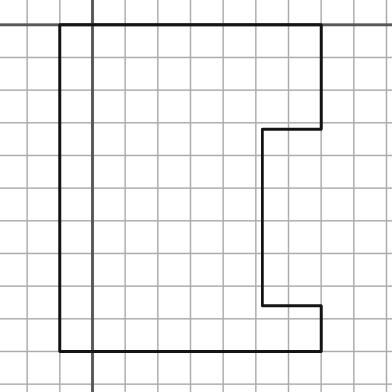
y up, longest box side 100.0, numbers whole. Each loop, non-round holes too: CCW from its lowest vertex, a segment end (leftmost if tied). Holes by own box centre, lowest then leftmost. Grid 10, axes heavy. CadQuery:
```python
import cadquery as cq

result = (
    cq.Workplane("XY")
    .moveTo(-10.0, -100.0)
    .lineTo(70.0, -100.0)
    .lineTo(70.0, -86.0)
    .lineTo(52.0, -86.0)
    .lineTo(52.0, -32.0)
    .lineTo(70.0, -32.0)
    .lineTo(70.0, 0.0)
    .lineTo(-10.0, 0.0)
    .close()
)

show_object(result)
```